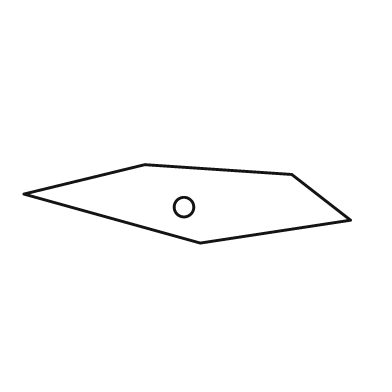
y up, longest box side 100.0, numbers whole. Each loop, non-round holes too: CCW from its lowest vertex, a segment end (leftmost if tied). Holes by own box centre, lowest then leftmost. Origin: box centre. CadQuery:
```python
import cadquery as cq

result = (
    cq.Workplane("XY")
    .moveTo(4.0, -12.0)
    .lineTo(50.0, -5.0)
    .lineTo(32.0, 9.0)
    .lineTo(-13.0, 12.0)
    .lineTo(-50.0, 3.0)
    .close()
    .moveTo(-1.0, -1.0)
    .circle(3.0)
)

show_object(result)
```